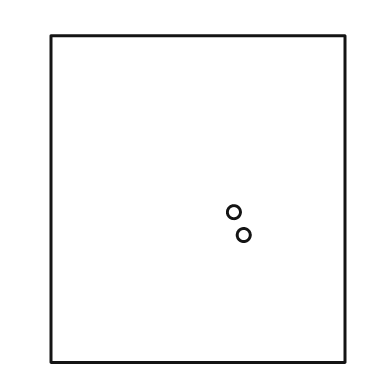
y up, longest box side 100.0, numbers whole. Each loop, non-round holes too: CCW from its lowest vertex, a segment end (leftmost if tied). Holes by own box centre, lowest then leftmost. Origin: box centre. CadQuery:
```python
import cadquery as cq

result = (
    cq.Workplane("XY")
    .moveTo(-45.0, -50.0)
    .lineTo(45.0, -50.0)
    .lineTo(45.0, 50.0)
    .lineTo(-45.0, 50.0)
    .close()
    .moveTo(14.0, -11.0)
    .circle(2.0)
    .moveTo(11.0, -4.0)
    .circle(2.0)
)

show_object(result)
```